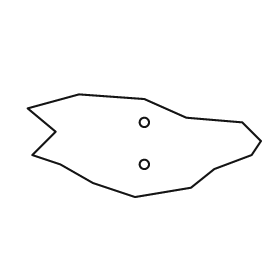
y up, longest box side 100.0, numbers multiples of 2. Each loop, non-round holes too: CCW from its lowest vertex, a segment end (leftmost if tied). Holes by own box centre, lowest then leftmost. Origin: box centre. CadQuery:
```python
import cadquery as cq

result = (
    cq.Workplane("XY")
    .moveTo(-4.0, -22.0)
    .lineTo(20.0, -18.0)
    .lineTo(30.0, -10.0)
    .lineTo(46.0, -4.0)
    .lineTo(50.0, 2.0)
    .lineTo(42.0, 10.0)
    .lineTo(18.0, 12.0)
    .lineTo(0.0, 20.0)
    .lineTo(-28.0, 22.0)
    .lineTo(-50.0, 16.0)
    .lineTo(-38.0, 6.0)
    .lineTo(-48.0, -4.0)
    .lineTo(-36.0, -8.0)
    .lineTo(-22.0, -16.0)
    .close()
    .moveTo(0.0, -8.0)
    .circle(2.0)
    .moveTo(0.0, 10.0)
    .circle(2.0)
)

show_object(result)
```